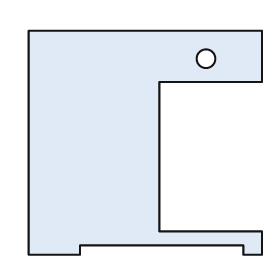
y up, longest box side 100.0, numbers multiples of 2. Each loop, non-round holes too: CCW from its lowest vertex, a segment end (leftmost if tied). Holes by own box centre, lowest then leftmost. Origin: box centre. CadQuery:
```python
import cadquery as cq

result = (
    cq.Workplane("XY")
    .moveTo(-50.0, -48.0)
    .lineTo(-28.0, -48.0)
    .lineTo(-28.0, -44.0)
    .lineTo(42.0, -44.0)
    .lineTo(42.0, -48.0)
    .lineTo(50.0, -48.0)
    .lineTo(50.0, -38.0)
    .lineTo(6.0, -38.0)
    .lineTo(6.0, 26.0)
    .lineTo(50.0, 26.0)
    .lineTo(50.0, 48.0)
    .lineTo(-50.0, 48.0)
    .close()
    .moveTo(26.0, 36.0)
    .circle(4.0)
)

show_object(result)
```